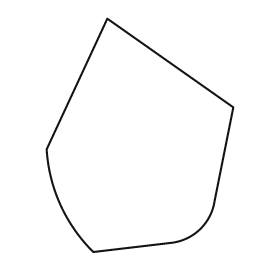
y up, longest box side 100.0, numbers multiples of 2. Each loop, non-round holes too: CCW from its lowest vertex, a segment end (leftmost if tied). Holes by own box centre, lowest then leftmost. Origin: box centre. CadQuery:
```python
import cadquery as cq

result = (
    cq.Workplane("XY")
    .moveTo(-20.0, -50.0)
    .lineTo(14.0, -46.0)
    .threePointArc((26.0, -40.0), (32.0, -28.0))
    .lineTo(40.0, 12.0)
    .lineTo(-14.0, 50.0)
    .lineTo(-40.0, -6.0)
    .threePointArc((-34.0, -30.0), (-20.0, -50.0))
    .close()
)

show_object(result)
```